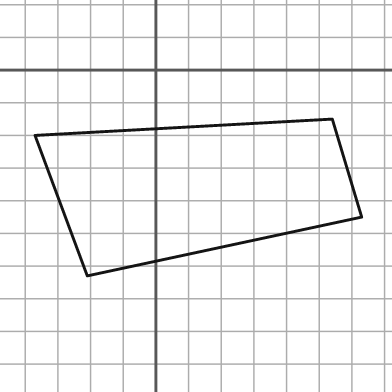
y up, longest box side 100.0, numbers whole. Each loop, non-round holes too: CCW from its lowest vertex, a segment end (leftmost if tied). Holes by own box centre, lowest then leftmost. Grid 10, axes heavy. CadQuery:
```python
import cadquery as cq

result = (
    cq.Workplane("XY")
    .moveTo(-21.0, -63.0)
    .lineTo(63.0, -45.0)
    .lineTo(54.0, -15.0)
    .lineTo(-37.0, -20.0)
    .close()
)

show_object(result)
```